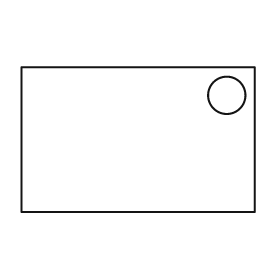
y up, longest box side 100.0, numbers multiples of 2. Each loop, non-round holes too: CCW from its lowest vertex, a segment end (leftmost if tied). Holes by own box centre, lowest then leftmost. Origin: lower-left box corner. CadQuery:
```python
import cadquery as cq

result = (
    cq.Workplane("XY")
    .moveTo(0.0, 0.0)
    .lineTo(100.0, 0.0)
    .lineTo(100.0, 62.0)
    .lineTo(0.0, 62.0)
    .close()
    .moveTo(88.0, 50.0)
    .circle(8.0)
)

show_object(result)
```